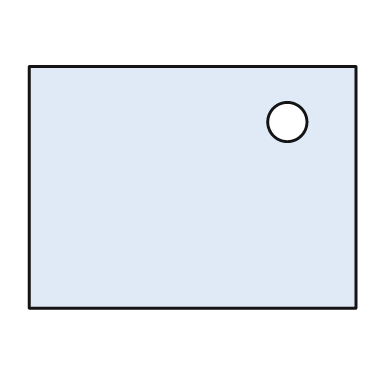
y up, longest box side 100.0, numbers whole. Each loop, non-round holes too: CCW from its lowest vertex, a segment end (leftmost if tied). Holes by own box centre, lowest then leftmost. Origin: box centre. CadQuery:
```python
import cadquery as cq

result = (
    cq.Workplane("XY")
    .moveTo(-50.0, -37.0)
    .lineTo(50.0, -37.0)
    .lineTo(50.0, 37.0)
    .lineTo(-50.0, 37.0)
    .close()
    .moveTo(29.0, 20.0)
    .circle(6.0)
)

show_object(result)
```